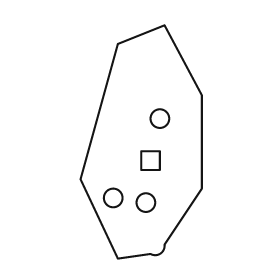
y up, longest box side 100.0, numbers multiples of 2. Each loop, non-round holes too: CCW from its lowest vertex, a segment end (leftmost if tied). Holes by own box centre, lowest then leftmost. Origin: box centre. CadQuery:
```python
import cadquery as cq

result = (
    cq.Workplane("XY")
    .moveTo(-10.0, -50.0)
    .lineTo(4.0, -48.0)
    .threePointArc((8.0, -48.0), (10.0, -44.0))
    .lineTo(26.0, -20.0)
    .lineTo(26.0, 20.0)
    .lineTo(10.0, 50.0)
    .lineTo(-10.0, 42.0)
    .lineTo(-26.0, -16.0)
    .close()
    .moveTo(2.0, -26.0)
    .circle(4.0)
    .moveTo(-12.0, -24.0)
    .circle(4.0)
    .moveTo(0.0, -12.0)
    .lineTo(8.0, -12.0)
    .lineTo(8.0, -4.0)
    .lineTo(0.0, -4.0)
    .close()
    .moveTo(8.0, 10.0)
    .circle(4.0)
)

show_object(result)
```